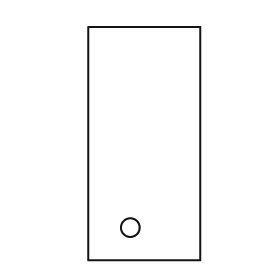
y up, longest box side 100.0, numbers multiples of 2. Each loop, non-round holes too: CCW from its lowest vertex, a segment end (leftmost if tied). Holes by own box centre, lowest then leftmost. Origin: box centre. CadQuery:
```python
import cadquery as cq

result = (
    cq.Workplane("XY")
    .moveTo(-24.0, -50.0)
    .lineTo(24.0, -50.0)
    .lineTo(24.0, 50.0)
    .lineTo(-24.0, 50.0)
    .close()
    .moveTo(-6.0, -36.0)
    .circle(4.0)
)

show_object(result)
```